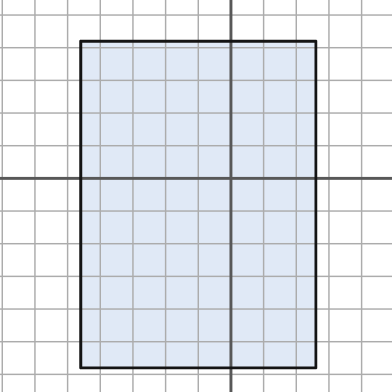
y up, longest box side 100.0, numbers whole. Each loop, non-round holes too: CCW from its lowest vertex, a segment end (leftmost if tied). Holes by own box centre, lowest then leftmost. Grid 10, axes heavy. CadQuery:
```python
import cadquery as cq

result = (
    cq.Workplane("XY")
    .moveTo(-46.0, -58.0)
    .lineTo(26.0, -58.0)
    .lineTo(26.0, 42.0)
    .lineTo(-46.0, 42.0)
    .close()
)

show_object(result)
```